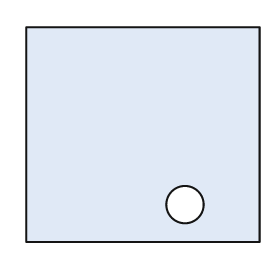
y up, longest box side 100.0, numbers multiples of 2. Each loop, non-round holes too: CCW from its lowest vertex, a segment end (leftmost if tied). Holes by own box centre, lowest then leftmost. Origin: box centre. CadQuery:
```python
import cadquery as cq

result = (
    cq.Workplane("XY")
    .moveTo(-50.0, -46.0)
    .lineTo(50.0, -46.0)
    .lineTo(50.0, 46.0)
    .lineTo(-50.0, 46.0)
    .close()
    .moveTo(18.0, -30.0)
    .circle(8.0)
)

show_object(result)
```